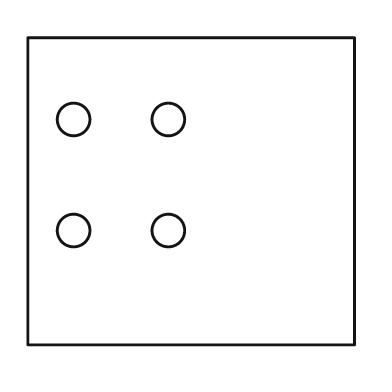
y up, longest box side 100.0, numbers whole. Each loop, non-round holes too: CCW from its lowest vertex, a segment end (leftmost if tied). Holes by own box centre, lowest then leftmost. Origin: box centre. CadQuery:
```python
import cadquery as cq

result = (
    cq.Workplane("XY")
    .moveTo(-50.0, -47.0)
    .lineTo(50.0, -47.0)
    .lineTo(50.0, 47.0)
    .lineTo(-50.0, 47.0)
    .close()
    .moveTo(-36.0, -12.0)
    .circle(5.0)
    .moveTo(-7.0, -12.0)
    .circle(5.0)
    .moveTo(-36.0, 22.0)
    .circle(5.0)
    .moveTo(-7.0, 22.0)
    .circle(5.0)
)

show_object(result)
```